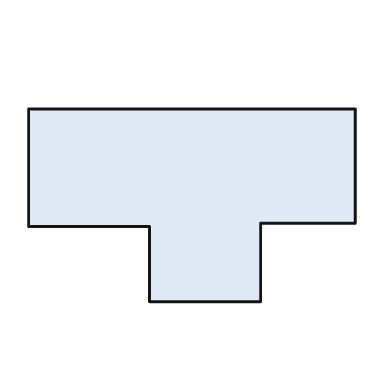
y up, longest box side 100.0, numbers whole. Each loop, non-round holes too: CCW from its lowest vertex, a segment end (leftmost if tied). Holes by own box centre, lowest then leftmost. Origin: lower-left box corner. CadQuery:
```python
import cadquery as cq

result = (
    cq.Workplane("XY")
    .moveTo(37.0, 0.0)
    .lineTo(71.0, 0.0)
    .lineTo(71.0, 24.0)
    .lineTo(100.0, 24.0)
    .lineTo(100.0, 59.0)
    .lineTo(0.0, 59.0)
    .lineTo(0.0, 23.0)
    .lineTo(37.0, 23.0)
    .close()
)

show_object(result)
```